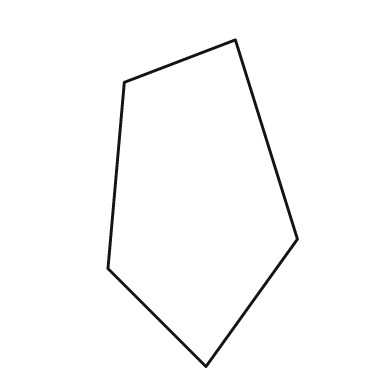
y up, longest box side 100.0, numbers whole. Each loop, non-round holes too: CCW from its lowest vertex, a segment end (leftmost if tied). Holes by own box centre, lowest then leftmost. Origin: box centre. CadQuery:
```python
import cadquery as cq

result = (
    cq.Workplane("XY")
    .moveTo(1.0, -50.0)
    .lineTo(29.0, -11.0)
    .lineTo(10.0, 50.0)
    .lineTo(-24.0, 37.0)
    .lineTo(-29.0, -20.0)
    .close()
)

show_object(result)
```